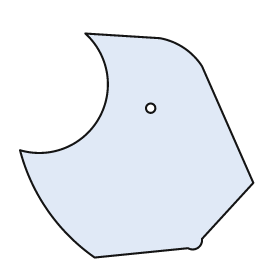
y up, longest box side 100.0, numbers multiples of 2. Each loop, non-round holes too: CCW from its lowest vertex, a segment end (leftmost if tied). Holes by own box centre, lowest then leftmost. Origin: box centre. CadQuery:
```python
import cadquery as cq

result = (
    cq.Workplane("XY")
    .moveTo(-18.0, -48.0)
    .lineTo(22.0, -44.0)
    .threePointArc((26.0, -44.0), (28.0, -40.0))
    .lineTo(50.0, -16.0)
    .lineTo(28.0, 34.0)
    .threePointArc((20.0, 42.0), (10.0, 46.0))
    .lineTo(-22.0, 48.0)
    .threePointArc((-16.0, 12.0), (-50.0, -2.0))
    .threePointArc((-38.0, -28.0), (-18.0, -48.0))
    .close()
    .moveTo(6.0, 16.0)
    .circle(2.0)
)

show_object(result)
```